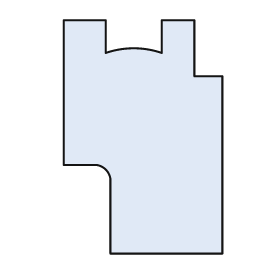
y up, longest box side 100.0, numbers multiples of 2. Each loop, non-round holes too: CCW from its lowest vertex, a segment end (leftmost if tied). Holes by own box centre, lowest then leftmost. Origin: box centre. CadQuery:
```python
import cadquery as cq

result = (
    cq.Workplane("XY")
    .moveTo(-14.0, -50.0)
    .lineTo(34.0, -50.0)
    .lineTo(34.0, 26.0)
    .lineTo(22.0, 26.0)
    .lineTo(22.0, 50.0)
    .lineTo(8.0, 50.0)
    .lineTo(8.0, 36.0)
    .threePointArc((-4.0, 38.0), (-16.0, 36.0))
    .lineTo(-16.0, 50.0)
    .lineTo(-34.0, 50.0)
    .lineTo(-34.0, -12.0)
    .lineTo(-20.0, -12.0)
    .threePointArc((-16.0, -14.0), (-14.0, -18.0))
    .close()
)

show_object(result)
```